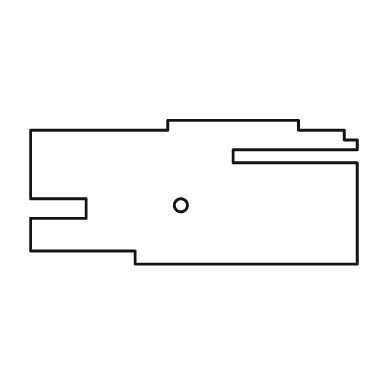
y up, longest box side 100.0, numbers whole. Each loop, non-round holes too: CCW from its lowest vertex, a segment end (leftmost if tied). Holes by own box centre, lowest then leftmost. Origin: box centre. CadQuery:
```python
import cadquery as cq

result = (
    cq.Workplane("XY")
    .moveTo(-18.0, -22.0)
    .lineTo(50.0, -22.0)
    .lineTo(50.0, 9.0)
    .lineTo(12.0, 9.0)
    .lineTo(12.0, 13.0)
    .lineTo(50.0, 13.0)
    .lineTo(50.0, 16.0)
    .lineTo(46.0, 16.0)
    .lineTo(46.0, 19.0)
    .lineTo(32.0, 19.0)
    .lineTo(32.0, 22.0)
    .lineTo(-8.0, 22.0)
    .lineTo(-8.0, 19.0)
    .lineTo(-50.0, 19.0)
    .lineTo(-50.0, -2.0)
    .lineTo(-33.0, -2.0)
    .lineTo(-33.0, -8.0)
    .lineTo(-50.0, -8.0)
    .lineTo(-50.0, -18.0)
    .lineTo(-18.0, -18.0)
    .close()
    .moveTo(-4.0, -4.0)
    .circle(2.0)
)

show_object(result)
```